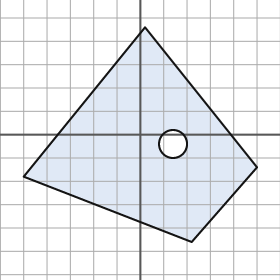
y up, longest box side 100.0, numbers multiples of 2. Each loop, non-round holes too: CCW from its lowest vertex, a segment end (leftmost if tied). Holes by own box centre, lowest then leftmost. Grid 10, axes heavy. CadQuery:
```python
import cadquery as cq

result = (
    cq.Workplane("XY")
    .moveTo(22.0, -46.0)
    .lineTo(50.0, -14.0)
    .lineTo(2.0, 46.0)
    .lineTo(-50.0, -18.0)
    .close()
    .moveTo(14.0, -4.0)
    .circle(6.0)
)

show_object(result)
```